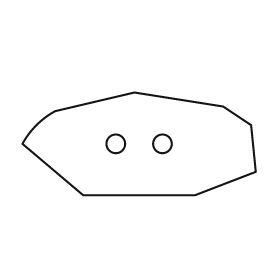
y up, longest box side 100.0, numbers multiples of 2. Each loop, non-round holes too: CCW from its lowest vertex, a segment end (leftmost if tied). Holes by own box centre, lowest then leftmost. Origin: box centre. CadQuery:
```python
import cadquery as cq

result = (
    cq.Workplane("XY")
    .moveTo(-24.0, -22.0)
    .lineTo(24.0, -22.0)
    .lineTo(50.0, -12.0)
    .lineTo(48.0, 8.0)
    .lineTo(36.0, 16.0)
    .lineTo(-2.0, 22.0)
    .lineTo(-36.0, 14.0)
    .threePointArc((-44.0, 8.0), (-50.0, 0.0))
    .close()
    .moveTo(-10.0, 0.0)
    .circle(4.0)
    .moveTo(10.0, 0.0)
    .circle(4.0)
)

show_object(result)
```